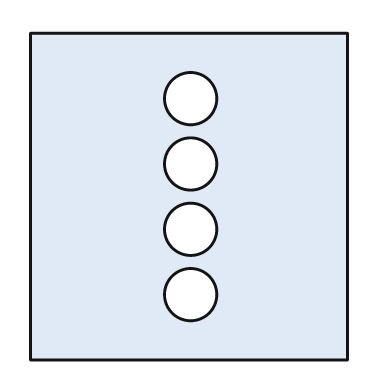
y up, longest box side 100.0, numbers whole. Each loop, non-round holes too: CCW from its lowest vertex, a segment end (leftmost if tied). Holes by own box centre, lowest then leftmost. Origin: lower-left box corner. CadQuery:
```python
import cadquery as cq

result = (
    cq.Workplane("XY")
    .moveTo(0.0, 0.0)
    .lineTo(97.0, 0.0)
    .lineTo(97.0, 100.0)
    .lineTo(0.0, 100.0)
    .close()
    .moveTo(49.0, 20.0)
    .circle(8.0)
    .moveTo(49.0, 40.0)
    .circle(8.0)
    .moveTo(49.0, 60.0)
    .circle(8.0)
    .moveTo(49.0, 80.0)
    .circle(8.0)
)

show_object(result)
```